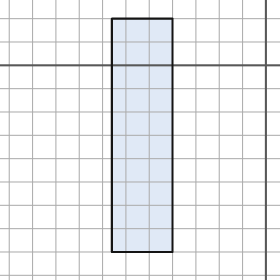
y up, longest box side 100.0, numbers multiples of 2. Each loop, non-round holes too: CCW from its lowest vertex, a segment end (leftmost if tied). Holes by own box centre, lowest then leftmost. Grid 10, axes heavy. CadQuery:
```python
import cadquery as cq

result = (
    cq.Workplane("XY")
    .moveTo(-66.0, -80.0)
    .lineTo(-40.0, -80.0)
    .lineTo(-40.0, 20.0)
    .lineTo(-66.0, 20.0)
    .close()
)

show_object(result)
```